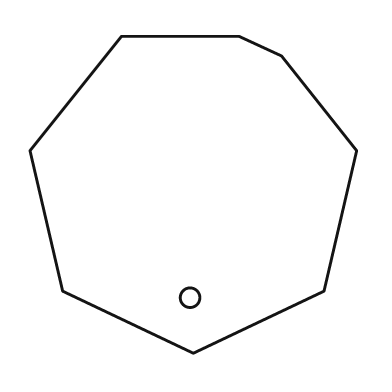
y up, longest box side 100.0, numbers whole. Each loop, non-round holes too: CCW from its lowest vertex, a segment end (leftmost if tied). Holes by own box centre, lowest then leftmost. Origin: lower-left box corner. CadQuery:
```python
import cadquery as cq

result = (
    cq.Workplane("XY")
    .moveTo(50.0, 0.0)
    .lineTo(90.0, 19.0)
    .lineTo(100.0, 62.0)
    .lineTo(77.0, 91.0)
    .lineTo(64.0, 97.0)
    .lineTo(28.0, 97.0)
    .lineTo(0.0, 62.0)
    .lineTo(10.0, 19.0)
    .close()
    .moveTo(49.0, 17.0)
    .circle(3.0)
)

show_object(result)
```